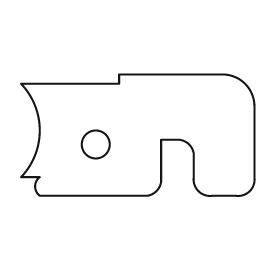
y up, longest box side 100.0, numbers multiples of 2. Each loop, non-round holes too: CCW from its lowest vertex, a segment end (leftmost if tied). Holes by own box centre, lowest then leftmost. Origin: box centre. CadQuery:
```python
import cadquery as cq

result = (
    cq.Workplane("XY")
    .moveTo(-42.0, -26.0)
    .lineTo(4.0, -26.0)
    .threePointArc((8.0, -24.0), (10.0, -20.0))
    .lineTo(10.0, -2.0)
    .lineTo(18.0, -2.0)
    .threePointArc((22.0, -4.0), (24.0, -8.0))
    .lineTo(24.0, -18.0)
    .threePointArc((26.0, -24.0), (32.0, -26.0))
    .lineTo(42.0, -26.0)
    .threePointArc((48.0, -24.0), (50.0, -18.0))
    .lineTo(50.0, 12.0)
    .threePointArc((46.0, 22.0), (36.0, 26.0))
    .lineTo(-8.0, 26.0)
    .lineTo(-8.0, 22.0)
    .lineTo(-50.0, 22.0)
    .threePointArc((-42.0, 2.0), (-50.0, -18.0))
    .lineTo(-42.0, -18.0)
    .threePointArc((-44.0, -22.0), (-42.0, -26.0))
    .close()
    .moveTo(-18.0, -4.0)
    .circle(6.0)
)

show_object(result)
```